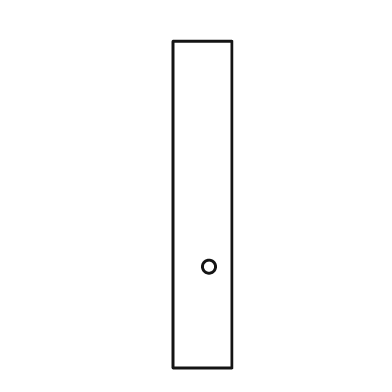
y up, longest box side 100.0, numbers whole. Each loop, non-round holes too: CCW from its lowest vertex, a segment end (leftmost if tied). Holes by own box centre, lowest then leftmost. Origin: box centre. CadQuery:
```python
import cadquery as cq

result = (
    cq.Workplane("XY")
    .moveTo(-9.0, -50.0)
    .lineTo(9.0, -50.0)
    .lineTo(9.0, 50.0)
    .lineTo(-9.0, 50.0)
    .close()
    .moveTo(2.0, -19.0)
    .circle(2.0)
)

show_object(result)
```